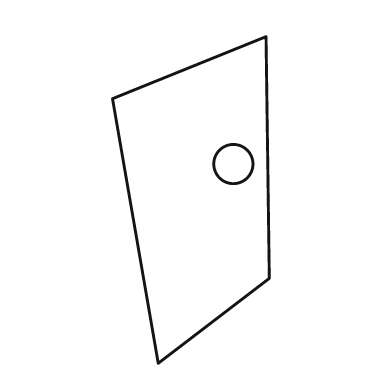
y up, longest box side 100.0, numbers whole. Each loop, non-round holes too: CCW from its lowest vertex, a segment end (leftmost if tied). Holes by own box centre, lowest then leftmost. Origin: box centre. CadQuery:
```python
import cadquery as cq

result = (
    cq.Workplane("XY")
    .moveTo(-10.0, -50.0)
    .lineTo(24.0, -24.0)
    .lineTo(23.0, 50.0)
    .lineTo(-24.0, 31.0)
    .close()
    .moveTo(13.0, 11.0)
    .circle(6.0)
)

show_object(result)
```